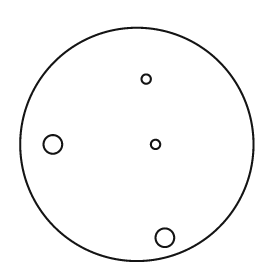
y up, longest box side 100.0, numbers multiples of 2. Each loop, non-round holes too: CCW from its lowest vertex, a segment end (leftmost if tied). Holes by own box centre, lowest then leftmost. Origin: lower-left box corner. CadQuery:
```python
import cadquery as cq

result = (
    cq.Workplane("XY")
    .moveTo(50.0, 50.0)
    .circle(50.0)
    .moveTo(62.0, 10.0)
    .circle(4.0)
    .moveTo(14.0, 50.0)
    .circle(4.0)
    .moveTo(58.0, 50.0)
    .circle(2.0)
    .moveTo(54.0, 78.0)
    .circle(2.0)
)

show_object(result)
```